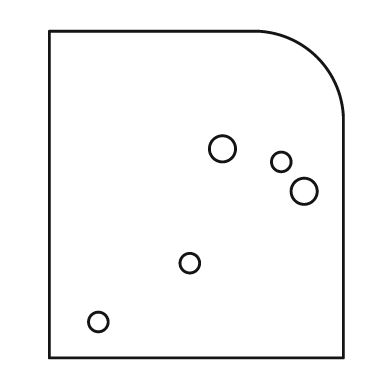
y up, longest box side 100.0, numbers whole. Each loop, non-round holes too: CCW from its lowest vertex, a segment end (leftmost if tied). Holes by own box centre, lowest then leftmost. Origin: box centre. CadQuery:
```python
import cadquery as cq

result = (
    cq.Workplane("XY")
    .moveTo(-45.0, -50.0)
    .lineTo(45.0, -50.0)
    .lineTo(45.0, 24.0)
    .threePointArc((37.0, 42.0), (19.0, 50.0))
    .lineTo(-45.0, 50.0)
    .close()
    .moveTo(-30.0, -39.0)
    .circle(3.0)
    .moveTo(-2.0, -21.0)
    .circle(3.0)
    .moveTo(33.0, 1.0)
    .circle(4.0)
    .moveTo(26.0, 10.0)
    .circle(3.0)
    .moveTo(8.0, 14.0)
    .circle(4.0)
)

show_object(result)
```